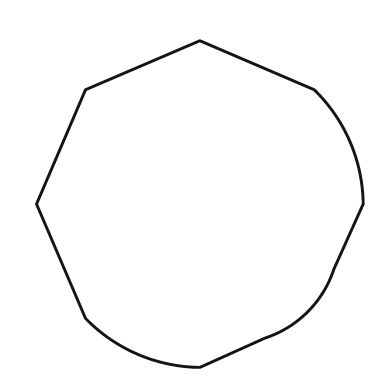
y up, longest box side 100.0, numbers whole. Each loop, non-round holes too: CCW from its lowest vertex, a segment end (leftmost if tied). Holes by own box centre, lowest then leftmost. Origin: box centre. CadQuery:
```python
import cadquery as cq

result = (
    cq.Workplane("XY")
    .moveTo(0.0, -50.0)
    .lineTo(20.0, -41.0)
    .threePointArc((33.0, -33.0), (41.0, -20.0))
    .lineTo(50.0, 0.0)
    .threePointArc((46.0, 19.0), (35.0, 35.0))
    .lineTo(0.0, 50.0)
    .lineTo(-35.0, 35.0)
    .lineTo(-50.0, 0.0)
    .lineTo(-35.0, -35.0)
    .threePointArc((-19.0, -46.0), (0.0, -50.0))
    .close()
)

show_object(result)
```